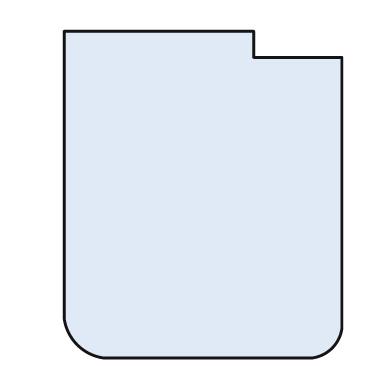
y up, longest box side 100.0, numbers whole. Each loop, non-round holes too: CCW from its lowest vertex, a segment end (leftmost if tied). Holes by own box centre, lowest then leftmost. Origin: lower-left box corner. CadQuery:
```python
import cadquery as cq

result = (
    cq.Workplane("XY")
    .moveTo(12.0, 0.0)
    .lineTo(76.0, 0.0)
    .threePointArc((82.0, 3.0), (85.0, 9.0))
    .lineTo(85.0, 92.0)
    .lineTo(58.0, 92.0)
    .lineTo(58.0, 100.0)
    .lineTo(0.0, 100.0)
    .lineTo(0.0, 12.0)
    .threePointArc((4.0, 4.0), (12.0, 0.0))
    .close()
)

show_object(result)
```